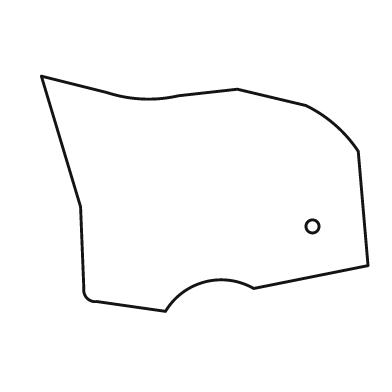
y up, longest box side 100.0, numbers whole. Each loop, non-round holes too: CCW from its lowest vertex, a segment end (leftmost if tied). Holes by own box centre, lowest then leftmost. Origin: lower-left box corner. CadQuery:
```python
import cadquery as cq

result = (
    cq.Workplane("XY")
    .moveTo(38.0, 0.0)
    .threePointArc((50.0, 9.0), (65.0, 7.0))
    .lineTo(100.0, 14.0)
    .lineTo(97.0, 49.0)
    .threePointArc((90.0, 57.0), (81.0, 63.0))
    .lineTo(60.0, 68.0)
    .lineTo(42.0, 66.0)
    .threePointArc((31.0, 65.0), (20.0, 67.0))
    .lineTo(0.0, 72.0)
    .lineTo(12.0, 32.0)
    .lineTo(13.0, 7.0)
    .threePointArc((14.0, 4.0), (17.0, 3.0))
    .close()
    .moveTo(83.0, 26.0)
    .circle(2.0)
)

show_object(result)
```